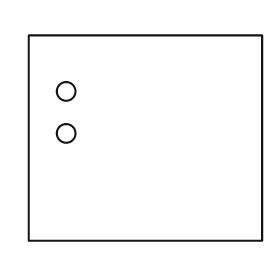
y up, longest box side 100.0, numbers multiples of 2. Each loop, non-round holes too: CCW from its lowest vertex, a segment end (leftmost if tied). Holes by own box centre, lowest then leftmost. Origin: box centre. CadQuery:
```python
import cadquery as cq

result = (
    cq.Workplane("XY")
    .moveTo(-50.0, -44.0)
    .lineTo(50.0, -44.0)
    .lineTo(50.0, 44.0)
    .lineTo(-50.0, 44.0)
    .close()
    .moveTo(-34.0, 2.0)
    .circle(4.0)
    .moveTo(-34.0, 20.0)
    .circle(4.0)
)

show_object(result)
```